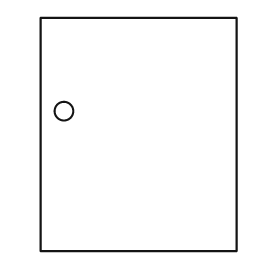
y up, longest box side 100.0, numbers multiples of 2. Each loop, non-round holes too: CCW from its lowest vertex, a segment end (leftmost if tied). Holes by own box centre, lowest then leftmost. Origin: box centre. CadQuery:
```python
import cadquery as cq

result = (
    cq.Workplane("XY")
    .moveTo(-42.0, -50.0)
    .lineTo(42.0, -50.0)
    .lineTo(42.0, 50.0)
    .lineTo(-42.0, 50.0)
    .close()
    .moveTo(-32.0, 10.0)
    .circle(4.0)
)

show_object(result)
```